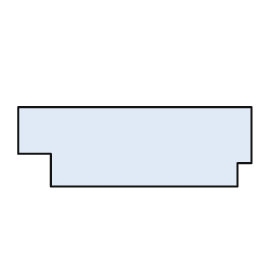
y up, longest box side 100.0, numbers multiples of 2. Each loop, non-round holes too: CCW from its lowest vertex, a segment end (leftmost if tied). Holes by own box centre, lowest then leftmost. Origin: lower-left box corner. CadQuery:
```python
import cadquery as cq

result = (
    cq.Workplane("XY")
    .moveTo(14.0, 0.0)
    .lineTo(94.0, 0.0)
    .lineTo(94.0, 10.0)
    .lineTo(100.0, 10.0)
    .lineTo(100.0, 34.0)
    .lineTo(0.0, 34.0)
    .lineTo(0.0, 14.0)
    .lineTo(14.0, 14.0)
    .close()
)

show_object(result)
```